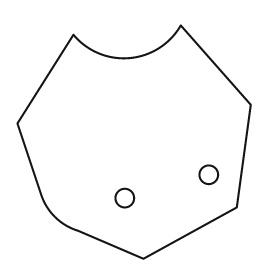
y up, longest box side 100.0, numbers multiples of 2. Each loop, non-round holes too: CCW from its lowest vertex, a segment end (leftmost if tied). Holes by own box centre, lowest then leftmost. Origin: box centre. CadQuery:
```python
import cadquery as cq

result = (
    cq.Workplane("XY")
    .moveTo(4.0, -50.0)
    .lineTo(44.0, -28.0)
    .lineTo(50.0, 16.0)
    .lineTo(20.0, 50.0)
    .threePointArc((-2.0, 36.0), (-26.0, 46.0))
    .lineTo(-50.0, 8.0)
    .lineTo(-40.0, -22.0)
    .threePointArc((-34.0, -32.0), (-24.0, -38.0))
    .close()
    .moveTo(-4.0, -24.0)
    .circle(4.0)
    .moveTo(32.0, -14.0)
    .circle(4.0)
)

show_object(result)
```